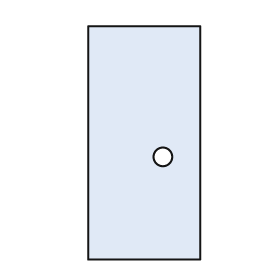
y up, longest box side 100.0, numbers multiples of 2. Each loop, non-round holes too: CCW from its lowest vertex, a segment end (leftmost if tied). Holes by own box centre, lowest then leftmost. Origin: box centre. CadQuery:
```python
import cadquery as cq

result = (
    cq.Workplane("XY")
    .moveTo(-24.0, -50.0)
    .lineTo(24.0, -50.0)
    .lineTo(24.0, 50.0)
    .lineTo(-24.0, 50.0)
    .close()
    .moveTo(8.0, -6.0)
    .circle(4.0)
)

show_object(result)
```